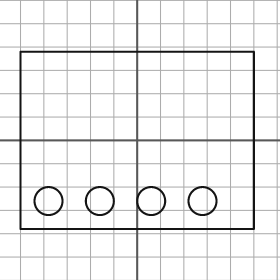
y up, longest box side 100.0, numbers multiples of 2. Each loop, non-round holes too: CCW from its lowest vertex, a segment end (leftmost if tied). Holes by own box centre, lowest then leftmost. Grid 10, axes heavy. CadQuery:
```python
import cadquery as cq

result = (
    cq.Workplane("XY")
    .moveTo(-50.0, -38.0)
    .lineTo(50.0, -38.0)
    .lineTo(50.0, 38.0)
    .lineTo(-50.0, 38.0)
    .close()
    .moveTo(-38.0, -26.0)
    .circle(6.0)
    .moveTo(-16.0, -26.0)
    .circle(6.0)
    .moveTo(6.0, -26.0)
    .circle(6.0)
    .moveTo(28.0, -26.0)
    .circle(6.0)
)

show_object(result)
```